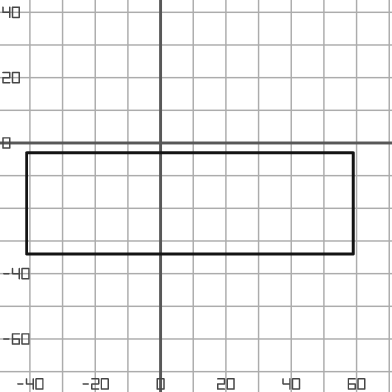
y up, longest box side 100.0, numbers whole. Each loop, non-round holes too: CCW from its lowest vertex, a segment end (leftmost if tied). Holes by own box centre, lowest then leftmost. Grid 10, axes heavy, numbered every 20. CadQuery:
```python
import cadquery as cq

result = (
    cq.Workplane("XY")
    .moveTo(-41.0, -34.0)
    .lineTo(59.0, -34.0)
    .lineTo(59.0, -3.0)
    .lineTo(-41.0, -3.0)
    .close()
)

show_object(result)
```